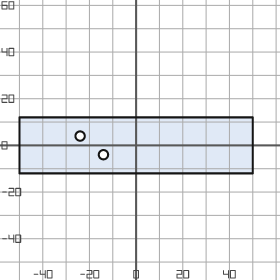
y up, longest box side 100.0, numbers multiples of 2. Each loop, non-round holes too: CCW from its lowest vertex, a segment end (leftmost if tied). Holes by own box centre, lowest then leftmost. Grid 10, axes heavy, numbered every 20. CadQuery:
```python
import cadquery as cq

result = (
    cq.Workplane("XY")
    .moveTo(-50.0, -12.0)
    .lineTo(50.0, -12.0)
    .lineTo(50.0, 12.0)
    .lineTo(-50.0, 12.0)
    .close()
    .moveTo(-14.0, -4.0)
    .circle(2.0)
    .moveTo(-24.0, 4.0)
    .circle(2.0)
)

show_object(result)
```